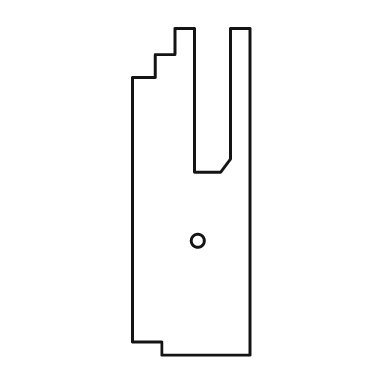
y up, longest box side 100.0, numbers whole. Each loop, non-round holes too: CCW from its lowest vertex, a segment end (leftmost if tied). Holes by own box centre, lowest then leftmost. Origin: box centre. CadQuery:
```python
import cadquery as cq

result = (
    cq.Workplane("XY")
    .moveTo(-9.0, -50.0)
    .lineTo(18.0, -50.0)
    .lineTo(18.0, 50.0)
    .lineTo(12.0, 50.0)
    .lineTo(12.0, 10.0)
    .lineTo(9.0, 6.0)
    .lineTo(1.0, 6.0)
    .lineTo(1.0, 50.0)
    .lineTo(-5.0, 50.0)
    .lineTo(-5.0, 42.0)
    .lineTo(-11.0, 42.0)
    .lineTo(-11.0, 35.0)
    .lineTo(-18.0, 35.0)
    .lineTo(-18.0, -46.0)
    .lineTo(-9.0, -46.0)
    .close()
    .moveTo(2.0, -15.0)
    .circle(2.0)
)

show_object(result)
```